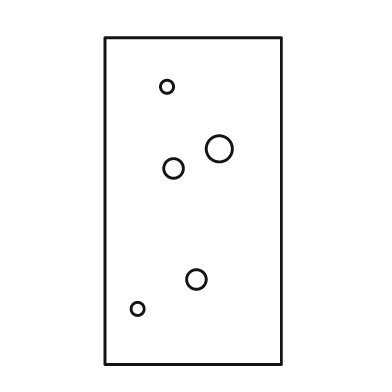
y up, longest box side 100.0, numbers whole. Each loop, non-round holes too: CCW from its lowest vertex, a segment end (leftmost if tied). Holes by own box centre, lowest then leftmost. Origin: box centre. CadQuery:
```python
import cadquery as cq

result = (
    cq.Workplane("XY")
    .moveTo(-27.0, -50.0)
    .lineTo(27.0, -50.0)
    .lineTo(27.0, 50.0)
    .lineTo(-27.0, 50.0)
    .close()
    .moveTo(-17.0, -33.0)
    .circle(2.0)
    .moveTo(1.0, -24.0)
    .circle(3.0)
    .moveTo(-6.0, 10.0)
    .circle(3.0)
    .moveTo(8.0, 16.0)
    .circle(4.0)
    .moveTo(-8.0, 35.0)
    .circle(2.0)
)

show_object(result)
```